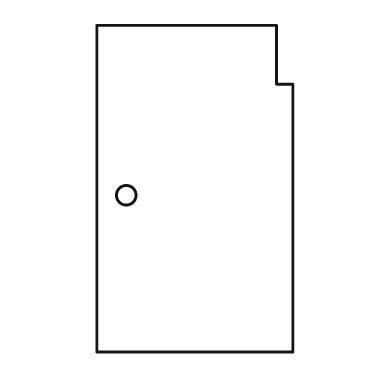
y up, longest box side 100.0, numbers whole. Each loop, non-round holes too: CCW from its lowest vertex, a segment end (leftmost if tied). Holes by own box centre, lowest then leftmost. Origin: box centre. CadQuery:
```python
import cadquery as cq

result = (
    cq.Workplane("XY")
    .moveTo(-30.0, -50.0)
    .lineTo(30.0, -50.0)
    .lineTo(30.0, 32.0)
    .lineTo(25.0, 32.0)
    .lineTo(25.0, 50.0)
    .lineTo(-30.0, 50.0)
    .close()
    .moveTo(-21.0, -2.0)
    .circle(3.0)
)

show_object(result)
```